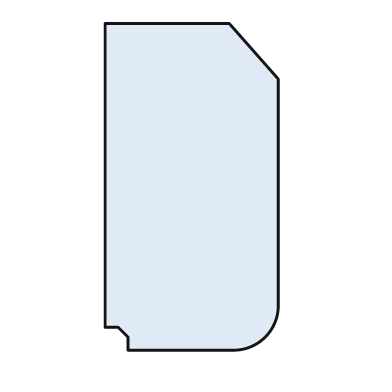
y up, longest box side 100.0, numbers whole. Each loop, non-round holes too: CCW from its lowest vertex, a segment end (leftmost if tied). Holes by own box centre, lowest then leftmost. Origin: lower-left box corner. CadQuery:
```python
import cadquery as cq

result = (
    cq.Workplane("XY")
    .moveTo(7.0, 0.0)
    .lineTo(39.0, 0.0)
    .threePointArc((49.0, 4.0), (53.0, 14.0))
    .lineTo(53.0, 83.0)
    .lineTo(38.0, 100.0)
    .lineTo(0.0, 100.0)
    .lineTo(0.0, 7.0)
    .lineTo(4.0, 7.0)
    .lineTo(7.0, 4.0)
    .close()
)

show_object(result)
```